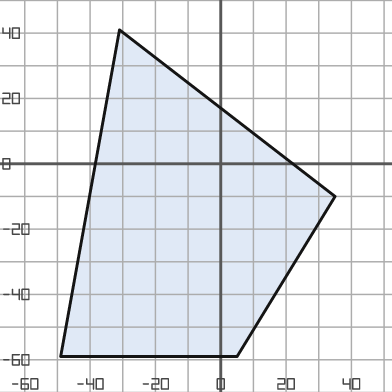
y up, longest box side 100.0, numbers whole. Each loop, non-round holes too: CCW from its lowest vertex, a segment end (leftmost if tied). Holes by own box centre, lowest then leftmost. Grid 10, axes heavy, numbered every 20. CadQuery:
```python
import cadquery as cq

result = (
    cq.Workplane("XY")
    .moveTo(-49.0, -59.0)
    .lineTo(5.0, -59.0)
    .lineTo(35.0, -10.0)
    .lineTo(-31.0, 41.0)
    .close()
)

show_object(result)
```